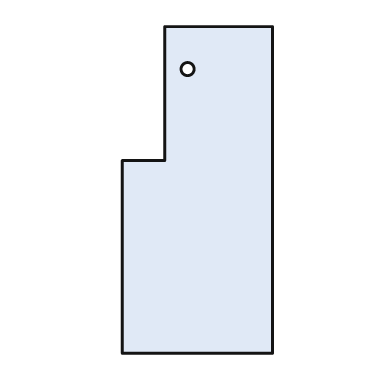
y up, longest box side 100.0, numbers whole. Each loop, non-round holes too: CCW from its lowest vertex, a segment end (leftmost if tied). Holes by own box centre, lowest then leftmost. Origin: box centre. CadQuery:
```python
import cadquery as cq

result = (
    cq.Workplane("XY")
    .moveTo(-23.0, -50.0)
    .lineTo(23.0, -50.0)
    .lineTo(23.0, 50.0)
    .lineTo(-10.0, 50.0)
    .lineTo(-10.0, 9.0)
    .lineTo(-23.0, 9.0)
    .close()
    .moveTo(-3.0, 37.0)
    .circle(2.0)
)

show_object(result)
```